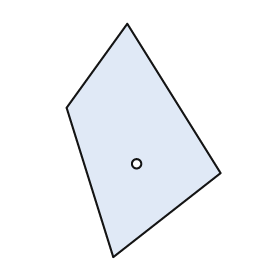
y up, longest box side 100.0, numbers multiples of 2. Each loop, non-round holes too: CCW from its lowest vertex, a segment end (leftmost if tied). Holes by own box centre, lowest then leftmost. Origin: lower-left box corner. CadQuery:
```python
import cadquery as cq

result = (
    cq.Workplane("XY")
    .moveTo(20.0, 0.0)
    .lineTo(66.0, 36.0)
    .lineTo(26.0, 100.0)
    .lineTo(0.0, 64.0)
    .close()
    .moveTo(30.0, 40.0)
    .circle(2.0)
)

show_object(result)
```